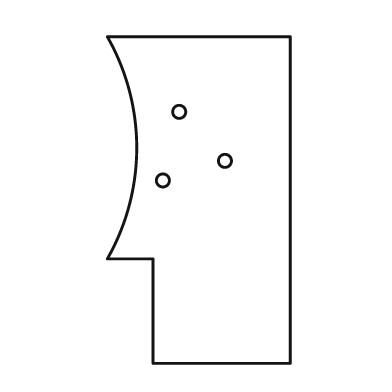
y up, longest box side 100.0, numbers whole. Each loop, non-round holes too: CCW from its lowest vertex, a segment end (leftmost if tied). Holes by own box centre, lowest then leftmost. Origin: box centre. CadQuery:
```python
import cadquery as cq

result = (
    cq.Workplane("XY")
    .moveTo(-14.0, -50.0)
    .lineTo(28.0, -50.0)
    .lineTo(28.0, 50.0)
    .lineTo(-28.0, 50.0)
    .threePointArc((-19.0, 16.0), (-28.0, -18.0))
    .lineTo(-14.0, -18.0)
    .close()
    .moveTo(-11.0, 6.0)
    .circle(2.0)
    .moveTo(8.0, 12.0)
    .circle(2.0)
    .moveTo(-6.0, 27.0)
    .circle(2.0)
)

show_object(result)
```